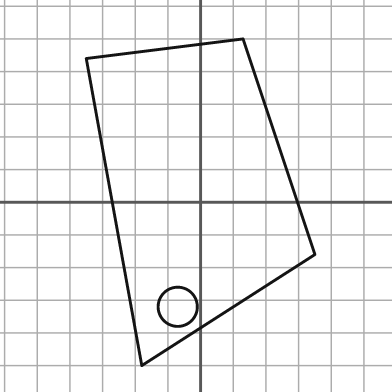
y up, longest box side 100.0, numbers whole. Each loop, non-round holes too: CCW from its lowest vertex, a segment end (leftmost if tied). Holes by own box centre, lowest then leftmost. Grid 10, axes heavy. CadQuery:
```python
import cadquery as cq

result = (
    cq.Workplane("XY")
    .moveTo(-18.0, -50.0)
    .lineTo(35.0, -16.0)
    .lineTo(13.0, 50.0)
    .lineTo(-35.0, 44.0)
    .close()
    .moveTo(-7.0, -32.0)
    .circle(6.0)
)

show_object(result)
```